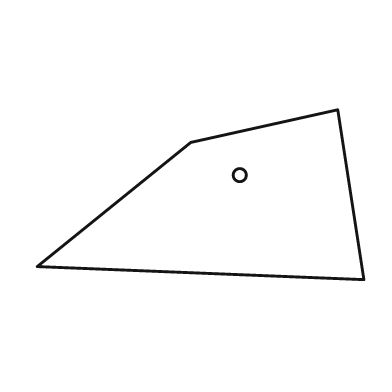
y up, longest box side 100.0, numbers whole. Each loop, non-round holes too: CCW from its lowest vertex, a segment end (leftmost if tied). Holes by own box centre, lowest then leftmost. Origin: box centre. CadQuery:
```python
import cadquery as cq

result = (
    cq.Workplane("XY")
    .moveTo(50.0, -26.0)
    .lineTo(42.0, 26.0)
    .lineTo(-3.0, 16.0)
    .lineTo(-50.0, -22.0)
    .close()
    .moveTo(12.0, 6.0)
    .circle(2.0)
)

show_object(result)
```